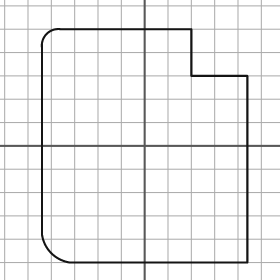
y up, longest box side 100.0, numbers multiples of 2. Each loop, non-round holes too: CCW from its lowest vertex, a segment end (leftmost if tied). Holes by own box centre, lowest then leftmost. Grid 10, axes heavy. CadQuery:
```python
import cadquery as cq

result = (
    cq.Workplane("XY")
    .moveTo(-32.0, -50.0)
    .lineTo(44.0, -50.0)
    .lineTo(44.0, 30.0)
    .lineTo(20.0, 30.0)
    .lineTo(20.0, 50.0)
    .lineTo(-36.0, 50.0)
    .threePointArc((-42.0, 48.0), (-44.0, 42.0))
    .lineTo(-44.0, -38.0)
    .threePointArc((-40.0, -46.0), (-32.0, -50.0))
    .close()
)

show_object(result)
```